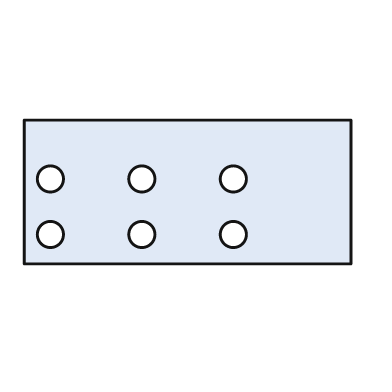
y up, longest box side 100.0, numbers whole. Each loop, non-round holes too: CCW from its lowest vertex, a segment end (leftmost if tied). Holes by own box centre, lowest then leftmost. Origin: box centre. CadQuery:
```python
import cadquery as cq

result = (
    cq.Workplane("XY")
    .moveTo(-50.0, -22.0)
    .lineTo(50.0, -22.0)
    .lineTo(50.0, 22.0)
    .lineTo(-50.0, 22.0)
    .close()
    .moveTo(-42.0, -13.0)
    .circle(4.0)
    .moveTo(-14.0, -13.0)
    .circle(4.0)
    .moveTo(14.0, -13.0)
    .circle(4.0)
    .moveTo(-42.0, 4.0)
    .circle(4.0)
    .moveTo(-14.0, 4.0)
    .circle(4.0)
    .moveTo(14.0, 4.0)
    .circle(4.0)
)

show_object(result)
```